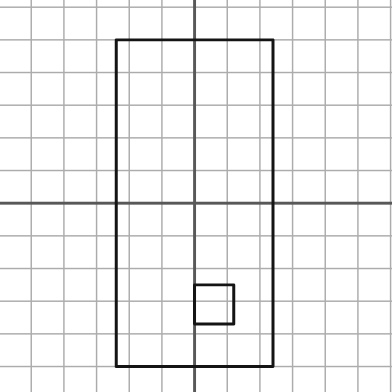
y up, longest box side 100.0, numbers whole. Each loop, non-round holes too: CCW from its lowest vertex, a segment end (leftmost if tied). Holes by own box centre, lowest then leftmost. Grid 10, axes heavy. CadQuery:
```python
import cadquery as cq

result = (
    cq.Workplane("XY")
    .moveTo(-24.0, -50.0)
    .lineTo(24.0, -50.0)
    .lineTo(24.0, 50.0)
    .lineTo(-24.0, 50.0)
    .close()
    .moveTo(0.0, -37.0)
    .lineTo(12.0, -37.0)
    .lineTo(12.0, -25.0)
    .lineTo(0.0, -25.0)
    .close()
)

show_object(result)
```